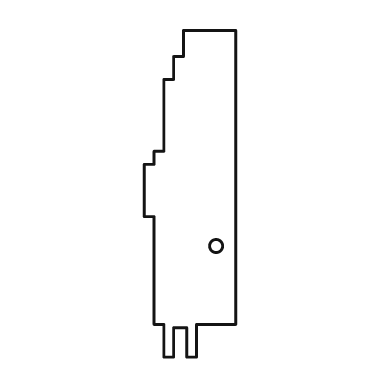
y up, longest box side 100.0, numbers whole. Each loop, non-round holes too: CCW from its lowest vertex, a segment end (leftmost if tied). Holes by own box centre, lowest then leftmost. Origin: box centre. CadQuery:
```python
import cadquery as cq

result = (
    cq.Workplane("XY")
    .moveTo(-8.0, -50.0)
    .lineTo(-5.0, -50.0)
    .lineTo(-5.0, -41.0)
    .lineTo(-1.0, -41.0)
    .lineTo(-1.0, -50.0)
    .lineTo(2.0, -50.0)
    .lineTo(2.0, -40.0)
    .lineTo(14.0, -40.0)
    .lineTo(14.0, 50.0)
    .lineTo(-2.0, 50.0)
    .lineTo(-2.0, 42.0)
    .lineTo(-5.0, 42.0)
    .lineTo(-5.0, 35.0)
    .lineTo(-8.0, 35.0)
    .lineTo(-8.0, 13.0)
    .lineTo(-11.0, 13.0)
    .lineTo(-11.0, 9.0)
    .lineTo(-14.0, 9.0)
    .lineTo(-14.0, -7.0)
    .lineTo(-11.0, -7.0)
    .lineTo(-11.0, -40.0)
    .lineTo(-8.0, -40.0)
    .close()
    .moveTo(8.0, -16.0)
    .circle(2.0)
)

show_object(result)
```